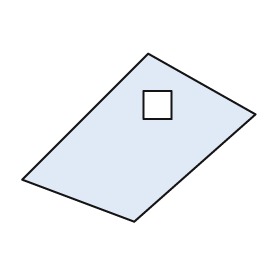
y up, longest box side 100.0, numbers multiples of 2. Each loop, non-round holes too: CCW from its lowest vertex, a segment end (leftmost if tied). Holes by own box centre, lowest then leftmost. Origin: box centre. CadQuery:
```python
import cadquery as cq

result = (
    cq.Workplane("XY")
    .moveTo(-2.0, -36.0)
    .lineTo(50.0, 10.0)
    .lineTo(4.0, 36.0)
    .lineTo(-50.0, -18.0)
    .close()
    .moveTo(2.0, 8.0)
    .lineTo(14.0, 8.0)
    .lineTo(14.0, 20.0)
    .lineTo(2.0, 20.0)
    .close()
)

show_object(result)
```